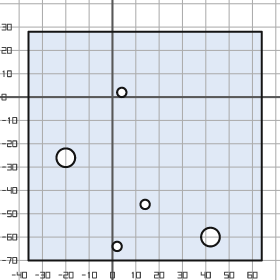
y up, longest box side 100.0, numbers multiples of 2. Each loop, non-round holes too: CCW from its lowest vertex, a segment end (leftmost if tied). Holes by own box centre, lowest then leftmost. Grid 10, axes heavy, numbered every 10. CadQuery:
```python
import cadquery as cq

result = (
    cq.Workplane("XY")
    .moveTo(-36.0, -70.0)
    .lineTo(64.0, -70.0)
    .lineTo(64.0, 28.0)
    .lineTo(-36.0, 28.0)
    .close()
    .moveTo(2.0, -64.0)
    .circle(2.0)
    .moveTo(42.0, -60.0)
    .circle(4.0)
    .moveTo(14.0, -46.0)
    .circle(2.0)
    .moveTo(-20.0, -26.0)
    .circle(4.0)
    .moveTo(4.0, 2.0)
    .circle(2.0)
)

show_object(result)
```